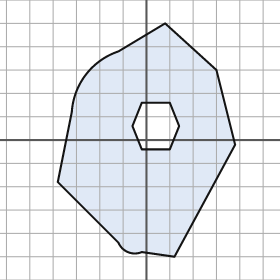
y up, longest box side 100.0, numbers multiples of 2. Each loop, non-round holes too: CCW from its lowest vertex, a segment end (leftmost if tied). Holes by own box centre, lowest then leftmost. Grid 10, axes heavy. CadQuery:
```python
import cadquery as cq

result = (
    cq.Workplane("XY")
    .moveTo(12.0, -50.0)
    .lineTo(38.0, -2.0)
    .lineTo(30.0, 30.0)
    .lineTo(8.0, 50.0)
    .lineTo(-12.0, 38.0)
    .threePointArc((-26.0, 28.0), (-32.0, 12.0))
    .lineTo(-38.0, -18.0)
    .lineTo(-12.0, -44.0)
    .threePointArc((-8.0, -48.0), (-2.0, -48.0))
    .close()
    .moveTo(-2.0, -4.0)
    .lineTo(10.0, -4.0)
    .lineTo(14.0, 6.0)
    .lineTo(10.0, 16.0)
    .lineTo(-2.0, 16.0)
    .lineTo(-6.0, 6.0)
    .close()
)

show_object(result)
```